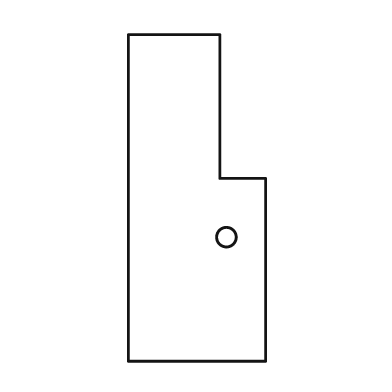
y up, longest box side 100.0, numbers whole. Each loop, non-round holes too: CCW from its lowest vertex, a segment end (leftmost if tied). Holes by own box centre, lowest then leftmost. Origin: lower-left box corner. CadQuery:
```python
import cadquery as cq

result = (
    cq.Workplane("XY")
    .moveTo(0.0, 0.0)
    .lineTo(42.0, 0.0)
    .lineTo(42.0, 56.0)
    .lineTo(28.0, 56.0)
    .lineTo(28.0, 100.0)
    .lineTo(0.0, 100.0)
    .close()
    .moveTo(30.0, 38.0)
    .circle(3.0)
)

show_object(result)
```